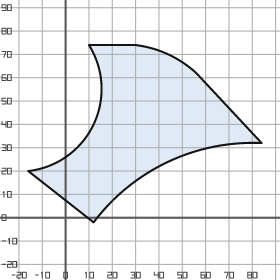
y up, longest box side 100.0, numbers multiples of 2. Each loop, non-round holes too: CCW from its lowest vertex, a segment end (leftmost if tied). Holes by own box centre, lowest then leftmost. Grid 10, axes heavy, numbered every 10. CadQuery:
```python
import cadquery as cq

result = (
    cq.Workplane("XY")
    .moveTo(12.0, -2.0)
    .threePointArc((44.0, 24.0), (84.0, 32.0))
    .lineTo(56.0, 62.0)
    .threePointArc((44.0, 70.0), (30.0, 74.0))
    .lineTo(10.0, 74.0)
    .threePointArc((12.0, 40.0), (-16.0, 20.0))
    .close()
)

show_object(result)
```